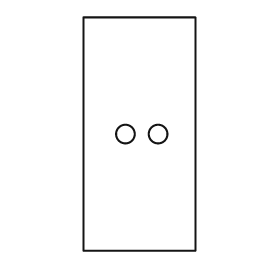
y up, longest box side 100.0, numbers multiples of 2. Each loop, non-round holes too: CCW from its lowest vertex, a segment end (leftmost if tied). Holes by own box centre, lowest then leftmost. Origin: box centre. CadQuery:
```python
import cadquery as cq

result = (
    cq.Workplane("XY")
    .moveTo(-24.0, -50.0)
    .lineTo(24.0, -50.0)
    .lineTo(24.0, 50.0)
    .lineTo(-24.0, 50.0)
    .close()
    .moveTo(-6.0, 0.0)
    .circle(4.0)
    .moveTo(8.0, 0.0)
    .circle(4.0)
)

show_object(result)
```